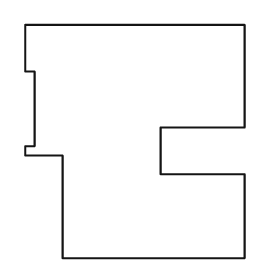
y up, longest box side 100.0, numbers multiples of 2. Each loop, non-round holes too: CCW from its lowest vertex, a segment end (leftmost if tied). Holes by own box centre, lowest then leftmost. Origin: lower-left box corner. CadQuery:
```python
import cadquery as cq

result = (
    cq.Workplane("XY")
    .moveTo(16.0, 0.0)
    .lineTo(94.0, 0.0)
    .lineTo(94.0, 36.0)
    .lineTo(58.0, 36.0)
    .lineTo(58.0, 56.0)
    .lineTo(94.0, 56.0)
    .lineTo(94.0, 100.0)
    .lineTo(0.0, 100.0)
    .lineTo(0.0, 80.0)
    .lineTo(4.0, 80.0)
    .lineTo(4.0, 48.0)
    .lineTo(0.0, 48.0)
    .lineTo(0.0, 44.0)
    .lineTo(16.0, 44.0)
    .close()
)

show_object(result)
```